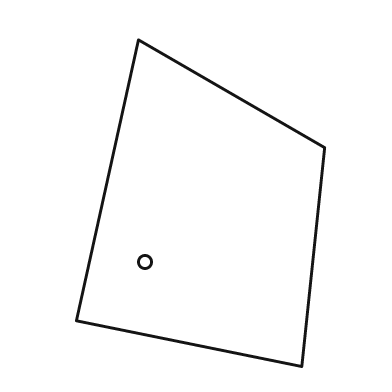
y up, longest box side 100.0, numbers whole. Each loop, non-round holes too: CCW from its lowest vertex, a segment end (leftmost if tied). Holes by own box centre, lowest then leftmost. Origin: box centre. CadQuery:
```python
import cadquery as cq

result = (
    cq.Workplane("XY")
    .moveTo(31.0, -50.0)
    .lineTo(38.0, 17.0)
    .lineTo(-19.0, 50.0)
    .lineTo(-38.0, -36.0)
    .close()
    .moveTo(-17.0, -18.0)
    .circle(2.0)
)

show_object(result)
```